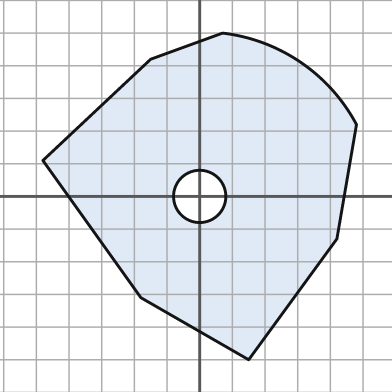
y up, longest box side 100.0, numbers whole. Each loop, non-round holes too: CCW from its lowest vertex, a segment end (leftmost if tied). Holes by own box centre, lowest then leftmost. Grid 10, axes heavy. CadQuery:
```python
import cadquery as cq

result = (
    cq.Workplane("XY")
    .moveTo(15.0, -50.0)
    .lineTo(42.0, -13.0)
    .lineTo(48.0, 22.0)
    .threePointArc((31.0, 41.0), (7.0, 50.0))
    .lineTo(-15.0, 42.0)
    .lineTo(-48.0, 11.0)
    .lineTo(-18.0, -31.0)
    .close()
    .moveTo(0.0, 0.0)
    .circle(8.0)
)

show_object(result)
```